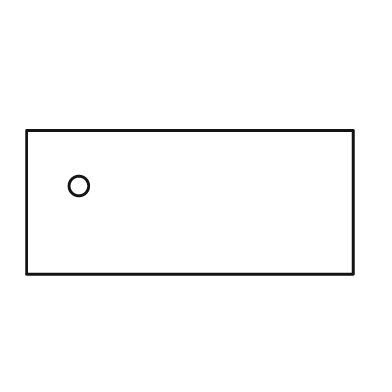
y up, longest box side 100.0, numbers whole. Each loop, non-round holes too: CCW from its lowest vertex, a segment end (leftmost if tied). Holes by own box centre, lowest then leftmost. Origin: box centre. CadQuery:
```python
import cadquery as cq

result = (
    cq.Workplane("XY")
    .moveTo(-50.0, -22.0)
    .lineTo(50.0, -22.0)
    .lineTo(50.0, 22.0)
    .lineTo(-50.0, 22.0)
    .close()
    .moveTo(-34.0, 5.0)
    .circle(3.0)
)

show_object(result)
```